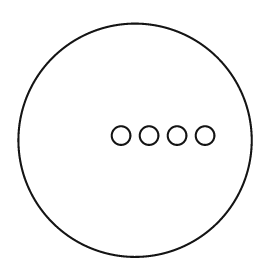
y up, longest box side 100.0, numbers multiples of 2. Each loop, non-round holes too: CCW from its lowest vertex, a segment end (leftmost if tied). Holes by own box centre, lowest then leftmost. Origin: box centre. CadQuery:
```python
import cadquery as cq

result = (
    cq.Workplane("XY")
    .moveTo(0.0, 0.0)
    .circle(50.0)
    .moveTo(-6.0, 2.0)
    .circle(4.0)
    .moveTo(6.0, 2.0)
    .circle(4.0)
    .moveTo(18.0, 2.0)
    .circle(4.0)
    .moveTo(30.0, 2.0)
    .circle(4.0)
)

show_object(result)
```